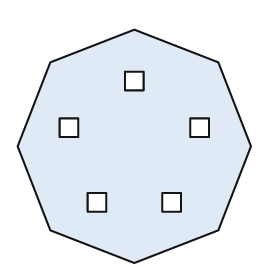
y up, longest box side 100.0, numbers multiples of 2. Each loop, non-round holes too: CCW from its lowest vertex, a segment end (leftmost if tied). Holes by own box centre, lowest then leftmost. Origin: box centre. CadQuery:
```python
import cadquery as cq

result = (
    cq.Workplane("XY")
    .moveTo(0.0, -50.0)
    .lineTo(36.0, -36.0)
    .lineTo(50.0, 0.0)
    .lineTo(36.0, 36.0)
    .lineTo(0.0, 50.0)
    .lineTo(-36.0, 36.0)
    .lineTo(-50.0, 0.0)
    .lineTo(-36.0, -36.0)
    .close()
    .moveTo(-20.0, -28.0)
    .lineTo(-12.0, -28.0)
    .lineTo(-12.0, -20.0)
    .lineTo(-20.0, -20.0)
    .close()
    .moveTo(12.0, -28.0)
    .lineTo(20.0, -28.0)
    .lineTo(20.0, -20.0)
    .lineTo(12.0, -20.0)
    .close()
    .moveTo(-32.0, 4.0)
    .lineTo(-24.0, 4.0)
    .lineTo(-24.0, 12.0)
    .lineTo(-32.0, 12.0)
    .close()
    .moveTo(24.0, 4.0)
    .lineTo(32.0, 4.0)
    .lineTo(32.0, 12.0)
    .lineTo(24.0, 12.0)
    .close()
    .moveTo(-4.0, 24.0)
    .lineTo(4.0, 24.0)
    .lineTo(4.0, 32.0)
    .lineTo(-4.0, 32.0)
    .close()
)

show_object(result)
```